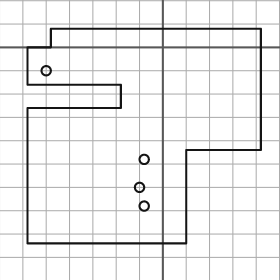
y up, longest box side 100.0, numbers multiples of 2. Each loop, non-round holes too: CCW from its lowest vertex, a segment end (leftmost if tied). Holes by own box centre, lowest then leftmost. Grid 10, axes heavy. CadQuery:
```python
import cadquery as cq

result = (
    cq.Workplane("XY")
    .moveTo(-58.0, -84.0)
    .lineTo(10.0, -84.0)
    .lineTo(10.0, -44.0)
    .lineTo(42.0, -44.0)
    .lineTo(42.0, 8.0)
    .lineTo(-48.0, 8.0)
    .lineTo(-48.0, 0.0)
    .lineTo(-58.0, 0.0)
    .lineTo(-58.0, -16.0)
    .lineTo(-18.0, -16.0)
    .lineTo(-18.0, -26.0)
    .lineTo(-58.0, -26.0)
    .close()
    .moveTo(-8.0, -68.0)
    .circle(2.0)
    .moveTo(-10.0, -60.0)
    .circle(2.0)
    .moveTo(-8.0, -48.0)
    .circle(2.0)
    .moveTo(-50.0, -10.0)
    .circle(2.0)
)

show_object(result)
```